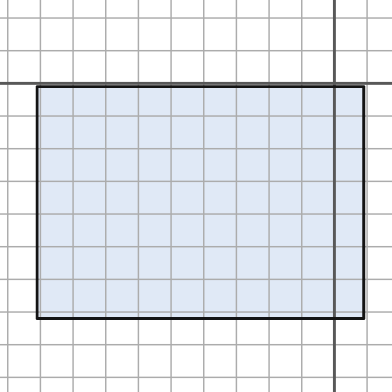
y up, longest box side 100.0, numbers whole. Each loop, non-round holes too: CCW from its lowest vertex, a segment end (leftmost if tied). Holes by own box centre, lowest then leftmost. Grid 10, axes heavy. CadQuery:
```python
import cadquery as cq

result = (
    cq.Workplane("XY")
    .moveTo(-91.0, -72.0)
    .lineTo(9.0, -72.0)
    .lineTo(9.0, -1.0)
    .lineTo(-91.0, -1.0)
    .close()
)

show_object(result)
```